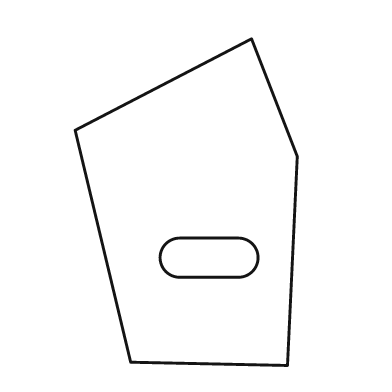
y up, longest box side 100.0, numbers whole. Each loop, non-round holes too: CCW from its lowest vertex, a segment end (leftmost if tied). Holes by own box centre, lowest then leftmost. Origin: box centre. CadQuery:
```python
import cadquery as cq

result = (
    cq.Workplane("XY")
    .moveTo(31.0, -50.0)
    .lineTo(34.0, 14.0)
    .lineTo(20.0, 50.0)
    .lineTo(-34.0, 22.0)
    .lineTo(-17.0, -49.0)
    .close()
    .moveTo(-2.0, -23.0)
    .lineTo(16.0, -23.0)
    .threePointArc((22.0, -17.0), (16.0, -11.0))
    .lineTo(-2.0, -11.0)
    .threePointArc((-8.0, -17.0), (-2.0, -23.0))
    .close()
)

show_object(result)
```